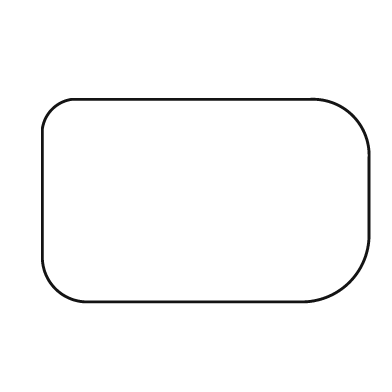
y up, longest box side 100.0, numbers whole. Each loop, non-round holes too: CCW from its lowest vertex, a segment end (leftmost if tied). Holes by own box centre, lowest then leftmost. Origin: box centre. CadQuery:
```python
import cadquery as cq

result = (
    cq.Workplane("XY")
    .moveTo(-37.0, -31.0)
    .lineTo(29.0, -31.0)
    .threePointArc((44.0, -25.0), (50.0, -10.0))
    .lineTo(50.0, 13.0)
    .threePointArc((45.0, 26.0), (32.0, 31.0))
    .lineTo(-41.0, 31.0)
    .threePointArc((-47.0, 28.0), (-50.0, 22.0))
    .lineTo(-50.0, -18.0)
    .threePointArc((-46.0, -27.0), (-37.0, -31.0))
    .close()
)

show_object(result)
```